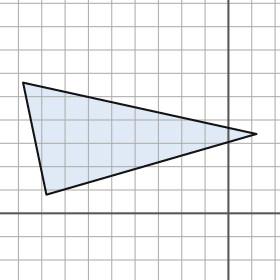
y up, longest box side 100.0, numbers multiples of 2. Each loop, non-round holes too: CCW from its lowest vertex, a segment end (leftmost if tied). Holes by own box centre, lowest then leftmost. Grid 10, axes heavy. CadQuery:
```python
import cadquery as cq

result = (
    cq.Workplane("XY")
    .moveTo(-78.0, 8.0)
    .lineTo(12.0, 34.0)
    .lineTo(-88.0, 56.0)
    .close()
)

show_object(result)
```